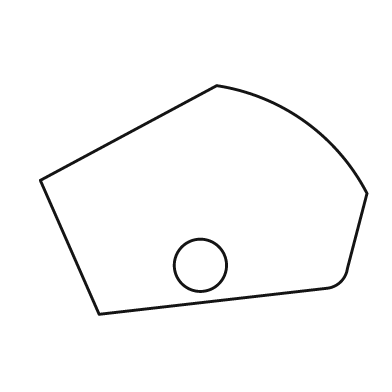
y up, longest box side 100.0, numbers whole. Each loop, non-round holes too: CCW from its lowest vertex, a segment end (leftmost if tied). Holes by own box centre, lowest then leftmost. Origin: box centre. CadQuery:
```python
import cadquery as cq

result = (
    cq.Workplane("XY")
    .moveTo(-32.0, -35.0)
    .lineTo(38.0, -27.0)
    .threePointArc((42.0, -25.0), (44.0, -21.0))
    .lineTo(50.0, 2.0)
    .threePointArc((31.0, 24.0), (4.0, 35.0))
    .lineTo(-50.0, 6.0)
    .close()
    .moveTo(-1.0, -20.0)
    .circle(8.0)
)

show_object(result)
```